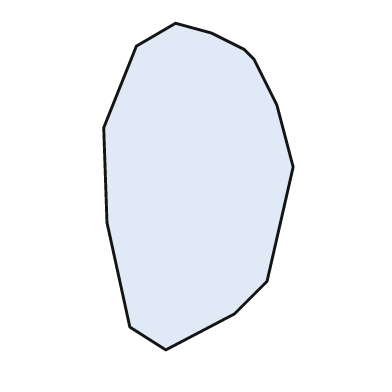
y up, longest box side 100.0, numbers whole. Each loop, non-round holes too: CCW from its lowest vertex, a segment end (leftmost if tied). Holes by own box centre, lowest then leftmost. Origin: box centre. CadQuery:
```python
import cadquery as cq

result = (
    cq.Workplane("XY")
    .moveTo(-10.0, -50.0)
    .lineTo(11.0, -39.0)
    .lineTo(21.0, -29.0)
    .lineTo(29.0, 6.0)
    .lineTo(24.0, 25.0)
    .lineTo(17.0, 39.0)
    .lineTo(14.0, 42.0)
    .lineTo(4.0, 47.0)
    .lineTo(-7.0, 50.0)
    .lineTo(-19.0, 43.0)
    .lineTo(-29.0, 18.0)
    .lineTo(-28.0, -11.0)
    .lineTo(-21.0, -43.0)
    .close()
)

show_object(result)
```